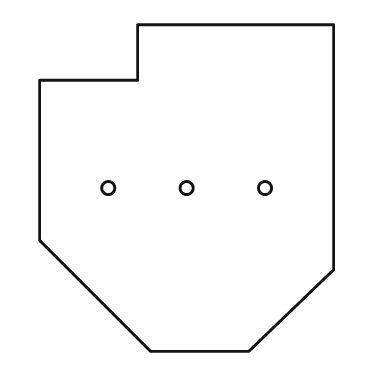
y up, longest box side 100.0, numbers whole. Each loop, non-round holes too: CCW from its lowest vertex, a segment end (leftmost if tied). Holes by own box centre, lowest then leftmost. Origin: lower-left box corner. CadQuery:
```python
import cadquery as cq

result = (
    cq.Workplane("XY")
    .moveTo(34.0, 0.0)
    .lineTo(64.0, 0.0)
    .lineTo(90.0, 25.0)
    .lineTo(90.0, 100.0)
    .lineTo(30.0, 100.0)
    .lineTo(30.0, 83.0)
    .lineTo(0.0, 83.0)
    .lineTo(0.0, 34.0)
    .close()
    .moveTo(21.0, 50.0)
    .circle(2.0)
    .moveTo(45.0, 50.0)
    .circle(2.0)
    .moveTo(69.0, 50.0)
    .circle(2.0)
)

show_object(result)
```